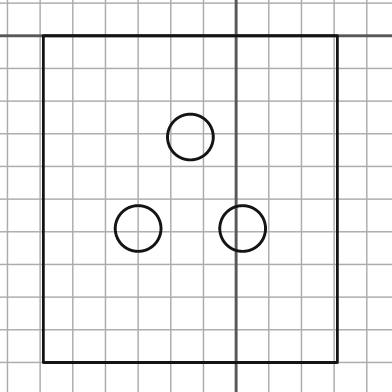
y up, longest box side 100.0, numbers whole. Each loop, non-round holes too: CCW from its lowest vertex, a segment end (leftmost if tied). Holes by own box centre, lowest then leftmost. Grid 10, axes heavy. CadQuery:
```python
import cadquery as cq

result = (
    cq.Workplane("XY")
    .moveTo(-59.0, -100.0)
    .lineTo(31.0, -100.0)
    .lineTo(31.0, 0.0)
    .lineTo(-59.0, 0.0)
    .close()
    .moveTo(-30.0, -59.0)
    .circle(7.0)
    .moveTo(2.0, -59.0)
    .circle(7.0)
    .moveTo(-14.0, -31.0)
    .circle(7.0)
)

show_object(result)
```